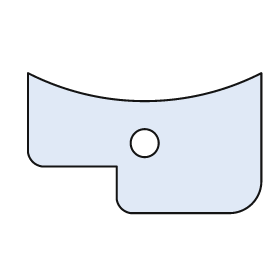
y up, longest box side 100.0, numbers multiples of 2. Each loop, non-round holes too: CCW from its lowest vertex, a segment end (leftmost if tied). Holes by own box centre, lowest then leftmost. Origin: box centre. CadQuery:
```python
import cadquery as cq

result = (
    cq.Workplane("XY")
    .moveTo(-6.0, -30.0)
    .lineTo(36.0, -30.0)
    .threePointArc((46.0, -26.0), (50.0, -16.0))
    .lineTo(50.0, 30.0)
    .threePointArc((0.0, 18.0), (-50.0, 30.0))
    .lineTo(-50.0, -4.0)
    .threePointArc((-48.0, -8.0), (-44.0, -10.0))
    .lineTo(-12.0, -10.0)
    .lineTo(-12.0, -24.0)
    .threePointArc((-10.0, -28.0), (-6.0, -30.0))
    .close()
    .moveTo(0.0, 0.0)
    .circle(6.0)
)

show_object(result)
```